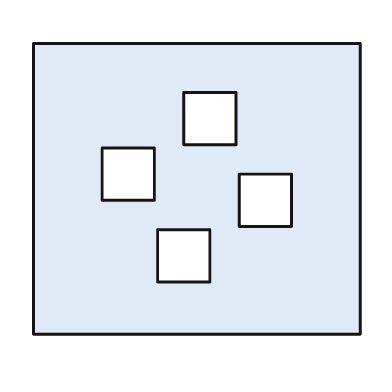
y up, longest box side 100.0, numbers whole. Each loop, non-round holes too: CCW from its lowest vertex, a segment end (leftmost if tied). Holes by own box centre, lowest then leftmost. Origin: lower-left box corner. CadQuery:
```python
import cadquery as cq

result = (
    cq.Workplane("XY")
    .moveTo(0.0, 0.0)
    .lineTo(100.0, 0.0)
    .lineTo(100.0, 89.0)
    .lineTo(0.0, 89.0)
    .close()
    .moveTo(38.0, 16.0)
    .lineTo(54.0, 16.0)
    .lineTo(54.0, 32.0)
    .lineTo(38.0, 32.0)
    .close()
    .moveTo(63.0, 33.0)
    .lineTo(79.0, 33.0)
    .lineTo(79.0, 49.0)
    .lineTo(63.0, 49.0)
    .close()
    .moveTo(21.0, 41.0)
    .lineTo(37.0, 41.0)
    .lineTo(37.0, 57.0)
    .lineTo(21.0, 57.0)
    .close()
    .moveTo(46.0, 58.0)
    .lineTo(62.0, 58.0)
    .lineTo(62.0, 74.0)
    .lineTo(46.0, 74.0)
    .close()
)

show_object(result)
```